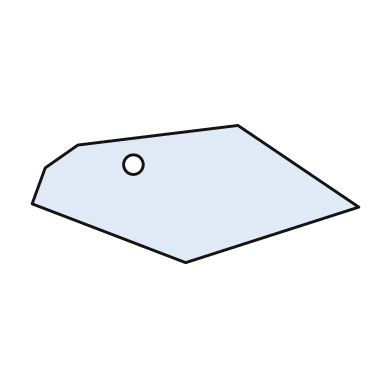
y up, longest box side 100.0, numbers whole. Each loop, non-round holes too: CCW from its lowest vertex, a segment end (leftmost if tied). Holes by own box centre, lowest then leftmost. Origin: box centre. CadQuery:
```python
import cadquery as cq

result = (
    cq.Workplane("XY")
    .moveTo(-3.0, -21.0)
    .lineTo(50.0, -4.0)
    .lineTo(13.0, 21.0)
    .lineTo(-36.0, 15.0)
    .lineTo(-46.0, 8.0)
    .lineTo(-50.0, -3.0)
    .close()
    .moveTo(-19.0, 9.0)
    .circle(3.0)
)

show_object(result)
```